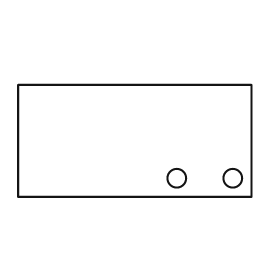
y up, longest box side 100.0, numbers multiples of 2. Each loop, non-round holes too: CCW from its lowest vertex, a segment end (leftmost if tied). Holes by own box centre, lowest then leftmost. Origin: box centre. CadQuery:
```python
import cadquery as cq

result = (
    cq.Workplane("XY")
    .moveTo(-50.0, -24.0)
    .lineTo(50.0, -24.0)
    .lineTo(50.0, 24.0)
    .lineTo(-50.0, 24.0)
    .close()
    .moveTo(18.0, -16.0)
    .circle(4.0)
    .moveTo(42.0, -16.0)
    .circle(4.0)
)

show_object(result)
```